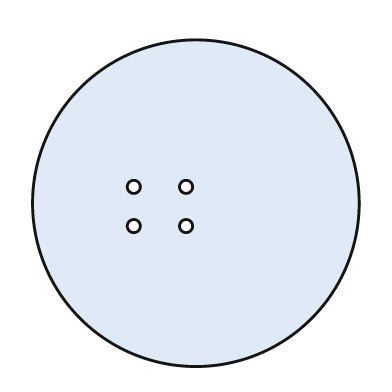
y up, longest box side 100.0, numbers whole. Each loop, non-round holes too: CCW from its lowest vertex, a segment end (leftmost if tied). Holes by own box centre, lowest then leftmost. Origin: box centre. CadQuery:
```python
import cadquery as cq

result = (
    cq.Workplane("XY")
    .moveTo(0.0, 0.0)
    .circle(50.0)
    .moveTo(-19.0, -7.0)
    .circle(2.0)
    .moveTo(-3.0, -7.0)
    .circle(2.0)
    .moveTo(-19.0, 5.0)
    .circle(2.0)
    .moveTo(-3.0, 5.0)
    .circle(2.0)
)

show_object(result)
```